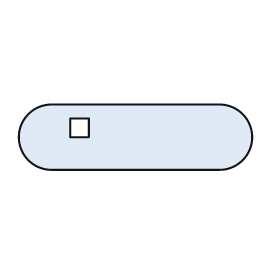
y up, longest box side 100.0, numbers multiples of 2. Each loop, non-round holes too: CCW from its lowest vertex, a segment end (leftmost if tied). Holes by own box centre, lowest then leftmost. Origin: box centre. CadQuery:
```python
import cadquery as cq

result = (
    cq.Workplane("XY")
    .moveTo(-36.0, -14.0)
    .lineTo(36.0, -14.0)
    .threePointArc((50.0, 0.0), (36.0, 14.0))
    .lineTo(-36.0, 14.0)
    .threePointArc((-50.0, 0.0), (-36.0, -14.0))
    .close()
    .moveTo(-28.0, 0.0)
    .lineTo(-20.0, 0.0)
    .lineTo(-20.0, 8.0)
    .lineTo(-28.0, 8.0)
    .close()
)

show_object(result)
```